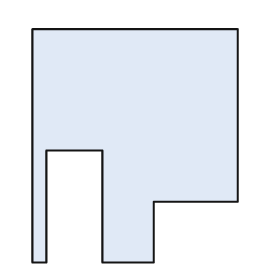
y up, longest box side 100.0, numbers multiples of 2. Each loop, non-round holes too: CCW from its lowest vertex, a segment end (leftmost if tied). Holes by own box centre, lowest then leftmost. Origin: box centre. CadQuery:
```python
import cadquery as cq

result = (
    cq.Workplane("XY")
    .moveTo(-44.0, -50.0)
    .lineTo(-38.0, -50.0)
    .lineTo(-38.0, -2.0)
    .lineTo(-14.0, -2.0)
    .lineTo(-14.0, -50.0)
    .lineTo(8.0, -50.0)
    .lineTo(8.0, -24.0)
    .lineTo(44.0, -24.0)
    .lineTo(44.0, 50.0)
    .lineTo(-44.0, 50.0)
    .close()
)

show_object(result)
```